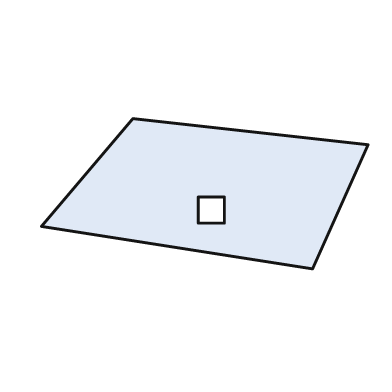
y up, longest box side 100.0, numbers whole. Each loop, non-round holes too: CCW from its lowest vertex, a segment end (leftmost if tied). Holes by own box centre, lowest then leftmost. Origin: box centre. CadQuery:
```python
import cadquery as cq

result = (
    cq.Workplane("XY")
    .moveTo(33.0, -23.0)
    .lineTo(50.0, 15.0)
    .lineTo(-22.0, 23.0)
    .lineTo(-50.0, -10.0)
    .close()
    .moveTo(-2.0, -9.0)
    .lineTo(6.0, -9.0)
    .lineTo(6.0, -1.0)
    .lineTo(-2.0, -1.0)
    .close()
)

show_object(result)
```